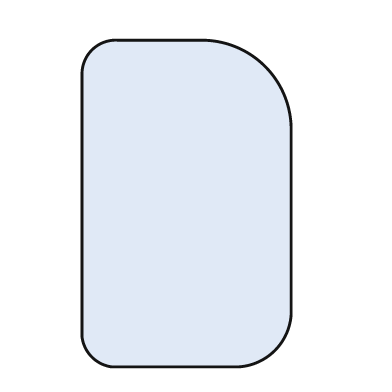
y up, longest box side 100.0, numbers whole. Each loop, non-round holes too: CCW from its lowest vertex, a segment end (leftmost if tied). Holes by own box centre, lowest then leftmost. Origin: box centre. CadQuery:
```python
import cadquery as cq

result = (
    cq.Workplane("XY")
    .moveTo(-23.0, -50.0)
    .lineTo(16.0, -50.0)
    .threePointArc((27.0, -45.0), (32.0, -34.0))
    .lineTo(32.0, 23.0)
    .threePointArc((24.0, 42.0), (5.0, 50.0))
    .lineTo(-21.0, 50.0)
    .threePointArc((-29.0, 47.0), (-32.0, 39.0))
    .lineTo(-32.0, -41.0)
    .threePointArc((-29.0, -47.0), (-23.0, -50.0))
    .close()
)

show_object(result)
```